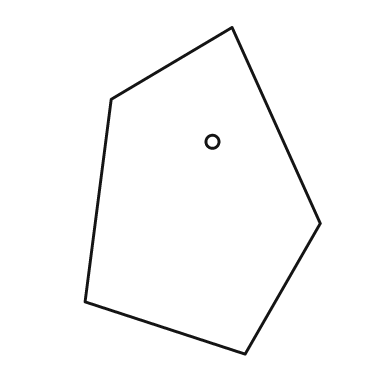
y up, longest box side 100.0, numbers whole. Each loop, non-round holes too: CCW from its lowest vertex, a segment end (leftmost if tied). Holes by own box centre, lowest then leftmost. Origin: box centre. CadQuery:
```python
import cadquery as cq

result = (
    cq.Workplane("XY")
    .moveTo(13.0, -50.0)
    .lineTo(36.0, -10.0)
    .lineTo(9.0, 50.0)
    .lineTo(-28.0, 28.0)
    .lineTo(-36.0, -34.0)
    .close()
    .moveTo(3.0, 15.0)
    .circle(2.0)
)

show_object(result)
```